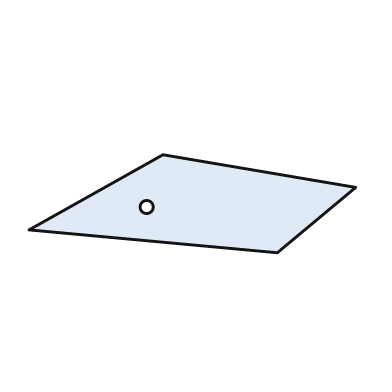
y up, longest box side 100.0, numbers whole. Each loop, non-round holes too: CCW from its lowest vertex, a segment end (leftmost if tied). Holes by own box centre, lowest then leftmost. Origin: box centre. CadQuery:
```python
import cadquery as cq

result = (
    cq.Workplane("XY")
    .moveTo(26.0, -15.0)
    .lineTo(50.0, 5.0)
    .lineTo(-9.0, 15.0)
    .lineTo(-50.0, -8.0)
    .close()
    .moveTo(-14.0, -1.0)
    .circle(2.0)
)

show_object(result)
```